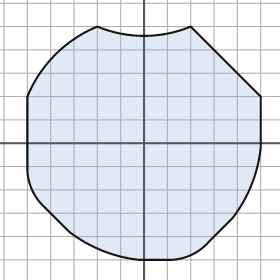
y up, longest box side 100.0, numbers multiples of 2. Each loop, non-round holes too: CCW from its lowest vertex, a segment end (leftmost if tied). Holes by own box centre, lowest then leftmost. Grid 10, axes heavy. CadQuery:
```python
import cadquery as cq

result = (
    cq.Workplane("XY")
    .moveTo(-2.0, -50.0)
    .lineTo(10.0, -50.0)
    .threePointArc((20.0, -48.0), (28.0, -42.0))
    .lineTo(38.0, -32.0)
    .threePointArc((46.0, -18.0), (50.0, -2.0))
    .lineTo(50.0, 20.0)
    .lineTo(20.0, 50.0)
    .threePointArc((0.0, 46.0), (-20.0, 50.0))
    .threePointArc((-38.0, 38.0), (-50.0, 20.0))
    .lineTo(-50.0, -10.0)
    .threePointArc((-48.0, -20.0), (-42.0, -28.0))
    .lineTo(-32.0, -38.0)
    .threePointArc((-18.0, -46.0), (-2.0, -50.0))
    .close()
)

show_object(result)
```